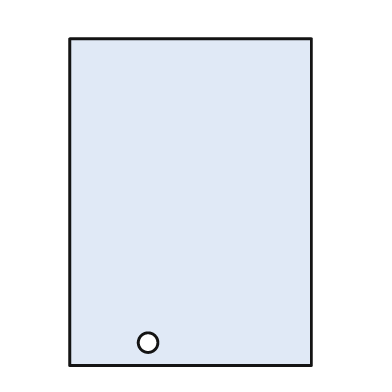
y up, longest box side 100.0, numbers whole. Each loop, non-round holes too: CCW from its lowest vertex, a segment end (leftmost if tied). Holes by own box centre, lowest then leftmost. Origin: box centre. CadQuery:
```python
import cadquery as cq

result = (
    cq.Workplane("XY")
    .moveTo(-37.0, -50.0)
    .lineTo(37.0, -50.0)
    .lineTo(37.0, 50.0)
    .lineTo(-37.0, 50.0)
    .close()
    .moveTo(-13.0, -43.0)
    .circle(3.0)
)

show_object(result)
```